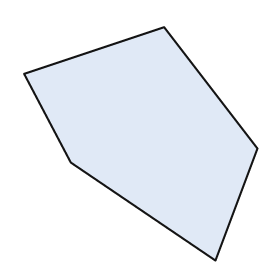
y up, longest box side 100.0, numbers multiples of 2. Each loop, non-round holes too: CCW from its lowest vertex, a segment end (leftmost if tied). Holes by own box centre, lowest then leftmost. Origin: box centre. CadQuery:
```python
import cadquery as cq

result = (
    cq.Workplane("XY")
    .moveTo(32.0, -50.0)
    .lineTo(50.0, -2.0)
    .lineTo(10.0, 50.0)
    .lineTo(-50.0, 30.0)
    .lineTo(-30.0, -8.0)
    .close()
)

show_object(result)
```